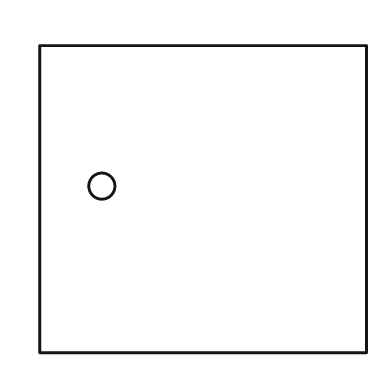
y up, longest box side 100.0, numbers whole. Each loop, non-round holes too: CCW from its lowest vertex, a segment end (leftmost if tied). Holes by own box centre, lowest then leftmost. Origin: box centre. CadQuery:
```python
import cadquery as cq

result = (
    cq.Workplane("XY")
    .moveTo(-50.0, -47.0)
    .lineTo(50.0, -47.0)
    .lineTo(50.0, 47.0)
    .lineTo(-50.0, 47.0)
    .close()
    .moveTo(-31.0, 4.0)
    .circle(4.0)
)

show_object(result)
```